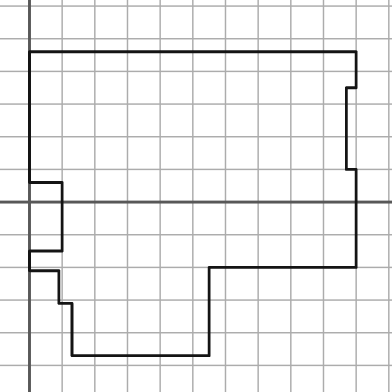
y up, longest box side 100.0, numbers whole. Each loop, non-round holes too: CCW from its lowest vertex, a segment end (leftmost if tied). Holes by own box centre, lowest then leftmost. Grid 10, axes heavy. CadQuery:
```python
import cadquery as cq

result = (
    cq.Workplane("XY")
    .moveTo(13.0, -47.0)
    .lineTo(55.0, -47.0)
    .lineTo(55.0, -20.0)
    .lineTo(100.0, -20.0)
    .lineTo(100.0, 10.0)
    .lineTo(97.0, 10.0)
    .lineTo(97.0, 35.0)
    .lineTo(100.0, 35.0)
    .lineTo(100.0, 46.0)
    .lineTo(0.0, 46.0)
    .lineTo(0.0, 6.0)
    .lineTo(10.0, 6.0)
    .lineTo(10.0, -15.0)
    .lineTo(0.0, -15.0)
    .lineTo(0.0, -21.0)
    .lineTo(9.0, -21.0)
    .lineTo(9.0, -31.0)
    .lineTo(13.0, -31.0)
    .close()
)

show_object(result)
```